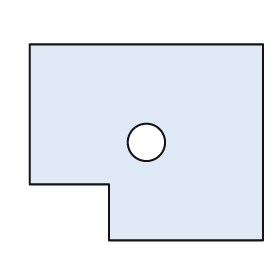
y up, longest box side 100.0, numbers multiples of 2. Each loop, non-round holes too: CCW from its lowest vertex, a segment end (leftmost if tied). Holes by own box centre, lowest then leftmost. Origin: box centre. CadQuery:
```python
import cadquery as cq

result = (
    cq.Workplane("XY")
    .moveTo(-16.0, -42.0)
    .lineTo(50.0, -42.0)
    .lineTo(50.0, 42.0)
    .lineTo(-50.0, 42.0)
    .lineTo(-50.0, -18.0)
    .lineTo(-16.0, -18.0)
    .close()
    .moveTo(0.0, 0.0)
    .circle(8.0)
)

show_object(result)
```